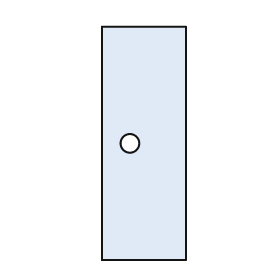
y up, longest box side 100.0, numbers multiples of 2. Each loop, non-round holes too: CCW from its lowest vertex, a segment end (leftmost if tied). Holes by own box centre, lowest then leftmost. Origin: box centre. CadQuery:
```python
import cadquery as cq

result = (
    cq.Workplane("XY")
    .moveTo(-18.0, -50.0)
    .lineTo(18.0, -50.0)
    .lineTo(18.0, 50.0)
    .lineTo(-18.0, 50.0)
    .close()
    .moveTo(-6.0, 0.0)
    .circle(4.0)
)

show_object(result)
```